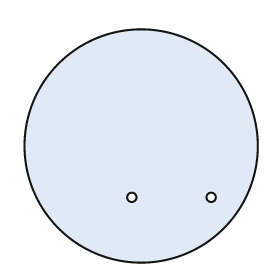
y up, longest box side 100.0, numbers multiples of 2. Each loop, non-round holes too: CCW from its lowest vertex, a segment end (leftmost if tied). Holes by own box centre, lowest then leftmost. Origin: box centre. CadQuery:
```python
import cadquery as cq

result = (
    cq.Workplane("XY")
    .moveTo(0.0, 0.0)
    .circle(50.0)
    .moveTo(-4.0, -22.0)
    .circle(2.0)
    .moveTo(30.0, -22.0)
    .circle(2.0)
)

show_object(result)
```